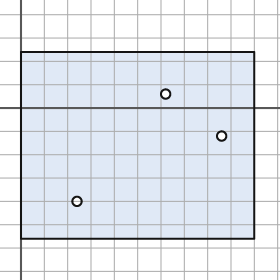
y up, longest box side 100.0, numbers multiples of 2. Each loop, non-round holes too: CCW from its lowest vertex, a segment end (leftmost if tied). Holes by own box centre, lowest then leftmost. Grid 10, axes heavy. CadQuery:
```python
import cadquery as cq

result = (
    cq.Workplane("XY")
    .moveTo(0.0, -56.0)
    .lineTo(100.0, -56.0)
    .lineTo(100.0, 24.0)
    .lineTo(0.0, 24.0)
    .close()
    .moveTo(24.0, -40.0)
    .circle(2.0)
    .moveTo(86.0, -12.0)
    .circle(2.0)
    .moveTo(62.0, 6.0)
    .circle(2.0)
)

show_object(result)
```